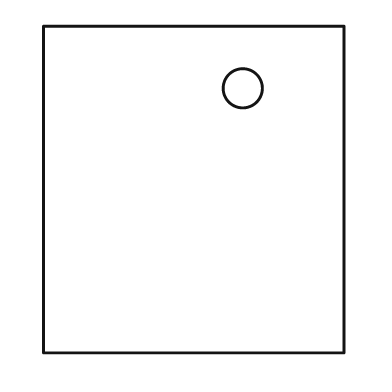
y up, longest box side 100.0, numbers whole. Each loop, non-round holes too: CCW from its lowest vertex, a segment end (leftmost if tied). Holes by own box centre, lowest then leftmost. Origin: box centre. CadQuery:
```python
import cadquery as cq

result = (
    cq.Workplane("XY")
    .moveTo(-46.0, -50.0)
    .lineTo(46.0, -50.0)
    .lineTo(46.0, 50.0)
    .lineTo(-46.0, 50.0)
    .close()
    .moveTo(15.0, 31.0)
    .circle(6.0)
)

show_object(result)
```